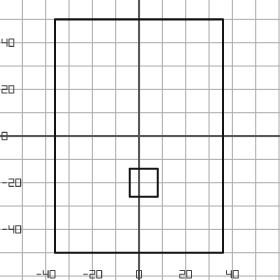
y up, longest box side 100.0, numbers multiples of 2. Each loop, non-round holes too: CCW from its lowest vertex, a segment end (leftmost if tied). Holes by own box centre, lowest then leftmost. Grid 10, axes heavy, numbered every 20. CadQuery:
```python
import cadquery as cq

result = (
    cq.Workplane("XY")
    .moveTo(-36.0, -50.0)
    .lineTo(36.0, -50.0)
    .lineTo(36.0, 50.0)
    .lineTo(-36.0, 50.0)
    .close()
    .moveTo(-4.0, -26.0)
    .lineTo(8.0, -26.0)
    .lineTo(8.0, -14.0)
    .lineTo(-4.0, -14.0)
    .close()
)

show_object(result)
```